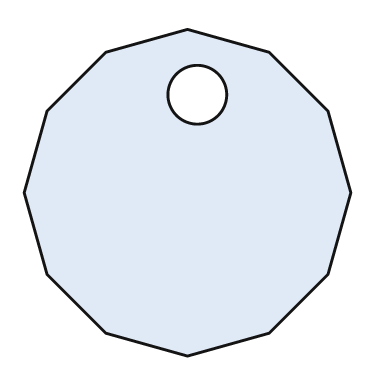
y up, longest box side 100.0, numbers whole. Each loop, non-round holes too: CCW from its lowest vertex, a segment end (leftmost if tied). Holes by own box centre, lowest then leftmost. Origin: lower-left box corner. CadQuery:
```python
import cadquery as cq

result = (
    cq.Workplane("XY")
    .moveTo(50.0, 0.0)
    .lineTo(75.0, 7.0)
    .lineTo(93.0, 25.0)
    .lineTo(100.0, 50.0)
    .lineTo(93.0, 75.0)
    .lineTo(75.0, 93.0)
    .lineTo(50.0, 100.0)
    .lineTo(25.0, 93.0)
    .lineTo(7.0, 75.0)
    .lineTo(0.0, 50.0)
    .lineTo(7.0, 25.0)
    .lineTo(25.0, 7.0)
    .close()
    .moveTo(53.0, 80.0)
    .circle(9.0)
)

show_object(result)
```